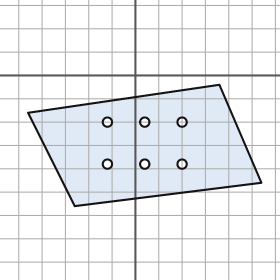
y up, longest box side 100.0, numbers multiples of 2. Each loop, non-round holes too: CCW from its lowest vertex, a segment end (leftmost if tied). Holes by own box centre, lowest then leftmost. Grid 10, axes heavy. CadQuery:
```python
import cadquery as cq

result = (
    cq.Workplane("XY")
    .moveTo(-26.0, -56.0)
    .lineTo(54.0, -46.0)
    .lineTo(36.0, -4.0)
    .lineTo(-46.0, -16.0)
    .close()
    .moveTo(-12.0, -38.0)
    .circle(2.0)
    .moveTo(4.0, -38.0)
    .circle(2.0)
    .moveTo(20.0, -38.0)
    .circle(2.0)
    .moveTo(-12.0, -20.0)
    .circle(2.0)
    .moveTo(4.0, -20.0)
    .circle(2.0)
    .moveTo(20.0, -20.0)
    .circle(2.0)
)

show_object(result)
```